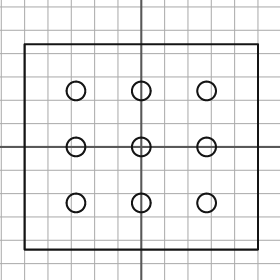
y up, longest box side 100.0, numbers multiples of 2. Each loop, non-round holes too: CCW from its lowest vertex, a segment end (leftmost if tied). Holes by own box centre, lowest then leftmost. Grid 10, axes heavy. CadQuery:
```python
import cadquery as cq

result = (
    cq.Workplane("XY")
    .moveTo(-50.0, -44.0)
    .lineTo(50.0, -44.0)
    .lineTo(50.0, 44.0)
    .lineTo(-50.0, 44.0)
    .close()
    .moveTo(-28.0, -24.0)
    .circle(4.0)
    .moveTo(0.0, -24.0)
    .circle(4.0)
    .moveTo(28.0, -24.0)
    .circle(4.0)
    .moveTo(-28.0, 0.0)
    .circle(4.0)
    .moveTo(0.0, 0.0)
    .circle(4.0)
    .moveTo(28.0, 0.0)
    .circle(4.0)
    .moveTo(-28.0, 24.0)
    .circle(4.0)
    .moveTo(0.0, 24.0)
    .circle(4.0)
    .moveTo(28.0, 24.0)
    .circle(4.0)
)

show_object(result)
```